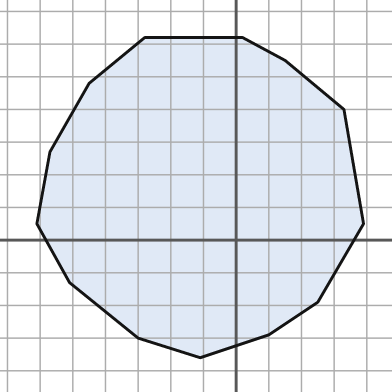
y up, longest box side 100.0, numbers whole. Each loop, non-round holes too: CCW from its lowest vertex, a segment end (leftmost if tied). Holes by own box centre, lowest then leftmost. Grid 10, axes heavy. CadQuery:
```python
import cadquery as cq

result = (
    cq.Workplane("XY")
    .moveTo(-11.0, -36.0)
    .lineTo(10.0, -29.0)
    .lineTo(25.0, -19.0)
    .lineTo(39.0, 5.0)
    .lineTo(33.0, 40.0)
    .lineTo(15.0, 55.0)
    .lineTo(2.0, 62.0)
    .lineTo(-28.0, 62.0)
    .lineTo(-45.0, 48.0)
    .lineTo(-57.0, 27.0)
    .lineTo(-61.0, 5.0)
    .lineTo(-51.0, -13.0)
    .lineTo(-30.0, -30.0)
    .close()
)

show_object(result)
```